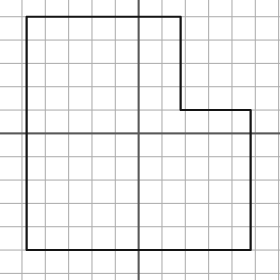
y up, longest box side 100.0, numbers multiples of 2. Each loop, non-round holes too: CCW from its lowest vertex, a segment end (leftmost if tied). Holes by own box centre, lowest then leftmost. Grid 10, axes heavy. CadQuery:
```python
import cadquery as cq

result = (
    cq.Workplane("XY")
    .moveTo(-48.0, -50.0)
    .lineTo(48.0, -50.0)
    .lineTo(48.0, 10.0)
    .lineTo(18.0, 10.0)
    .lineTo(18.0, 50.0)
    .lineTo(-48.0, 50.0)
    .close()
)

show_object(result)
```